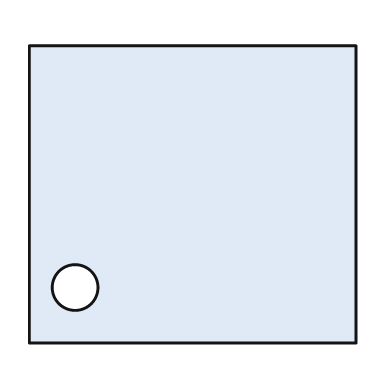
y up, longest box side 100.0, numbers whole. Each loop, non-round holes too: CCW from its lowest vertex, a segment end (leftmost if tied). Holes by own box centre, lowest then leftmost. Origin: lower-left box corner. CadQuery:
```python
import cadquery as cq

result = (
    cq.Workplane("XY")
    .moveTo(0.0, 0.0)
    .lineTo(100.0, 0.0)
    .lineTo(100.0, 91.0)
    .lineTo(0.0, 91.0)
    .close()
    .moveTo(14.0, 17.0)
    .circle(7.0)
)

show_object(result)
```